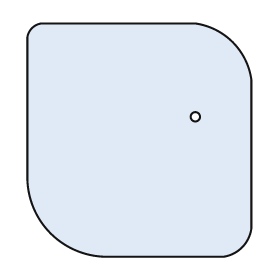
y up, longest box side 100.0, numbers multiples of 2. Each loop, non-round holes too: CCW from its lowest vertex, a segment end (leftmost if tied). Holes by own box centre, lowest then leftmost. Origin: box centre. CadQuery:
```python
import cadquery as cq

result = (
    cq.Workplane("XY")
    .moveTo(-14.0, -50.0)
    .lineTo(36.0, -50.0)
    .threePointArc((44.0, -46.0), (48.0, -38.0))
    .lineTo(48.0, 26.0)
    .threePointArc((40.0, 42.0), (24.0, 50.0))
    .lineTo(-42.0, 50.0)
    .threePointArc((-46.0, 48.0), (-48.0, 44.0))
    .lineTo(-48.0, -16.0)
    .threePointArc((-38.0, -40.0), (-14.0, -50.0))
    .close()
    .moveTo(24.0, 10.0)
    .circle(2.0)
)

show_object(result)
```